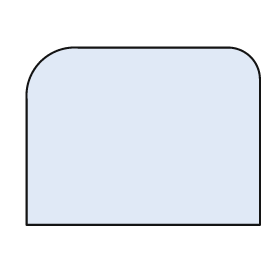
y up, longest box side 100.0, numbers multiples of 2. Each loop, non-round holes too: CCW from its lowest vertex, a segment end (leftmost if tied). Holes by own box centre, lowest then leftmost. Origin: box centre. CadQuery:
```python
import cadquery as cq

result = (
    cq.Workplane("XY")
    .moveTo(-50.0, -38.0)
    .lineTo(50.0, -38.0)
    .lineTo(50.0, 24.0)
    .threePointArc((46.0, 34.0), (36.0, 38.0))
    .lineTo(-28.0, 38.0)
    .threePointArc((-44.0, 32.0), (-50.0, 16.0))
    .close()
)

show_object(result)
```